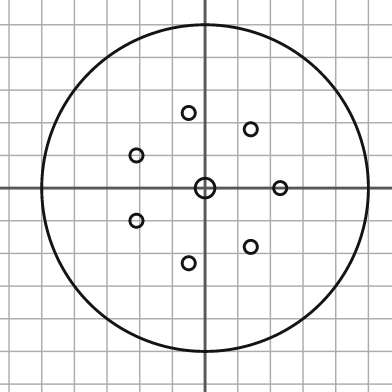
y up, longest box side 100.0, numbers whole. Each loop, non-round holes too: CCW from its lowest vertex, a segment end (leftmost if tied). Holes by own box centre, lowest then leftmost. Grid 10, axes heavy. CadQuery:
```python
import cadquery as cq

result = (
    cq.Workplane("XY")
    .moveTo(0.0, 0.0)
    .circle(50.0)
    .moveTo(-5.0, -23.0)
    .circle(2.0)
    .moveTo(14.0, -18.0)
    .circle(2.0)
    .moveTo(-21.0, -10.0)
    .circle(2.0)
    .moveTo(0.0, 0.0)
    .circle(3.0)
    .moveTo(23.0, 0.0)
    .circle(2.0)
    .moveTo(-21.0, 10.0)
    .circle(2.0)
    .moveTo(14.0, 18.0)
    .circle(2.0)
    .moveTo(-5.0, 23.0)
    .circle(2.0)
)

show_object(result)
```